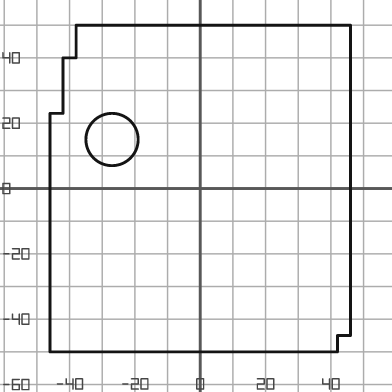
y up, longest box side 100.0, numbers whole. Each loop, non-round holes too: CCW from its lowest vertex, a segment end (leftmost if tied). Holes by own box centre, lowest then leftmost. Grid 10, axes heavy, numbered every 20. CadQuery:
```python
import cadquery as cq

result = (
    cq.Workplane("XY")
    .moveTo(-46.0, -50.0)
    .lineTo(42.0, -50.0)
    .lineTo(42.0, -45.0)
    .lineTo(46.0, -45.0)
    .lineTo(46.0, 50.0)
    .lineTo(-38.0, 50.0)
    .lineTo(-38.0, 40.0)
    .lineTo(-42.0, 40.0)
    .lineTo(-42.0, 23.0)
    .lineTo(-46.0, 23.0)
    .close()
    .moveTo(-27.0, 15.0)
    .circle(8.0)
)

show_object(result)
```